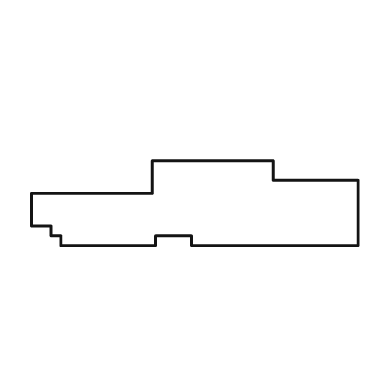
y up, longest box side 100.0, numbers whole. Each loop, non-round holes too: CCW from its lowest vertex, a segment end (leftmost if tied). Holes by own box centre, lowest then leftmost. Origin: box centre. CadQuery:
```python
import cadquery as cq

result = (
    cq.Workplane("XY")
    .moveTo(-41.0, -13.0)
    .lineTo(-12.0, -13.0)
    .lineTo(-12.0, -10.0)
    .lineTo(-1.0, -10.0)
    .lineTo(-1.0, -13.0)
    .lineTo(50.0, -13.0)
    .lineTo(50.0, 7.0)
    .lineTo(24.0, 7.0)
    .lineTo(24.0, 13.0)
    .lineTo(-13.0, 13.0)
    .lineTo(-13.0, 3.0)
    .lineTo(-50.0, 3.0)
    .lineTo(-50.0, -7.0)
    .lineTo(-44.0, -7.0)
    .lineTo(-44.0, -10.0)
    .lineTo(-41.0, -10.0)
    .close()
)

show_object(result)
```